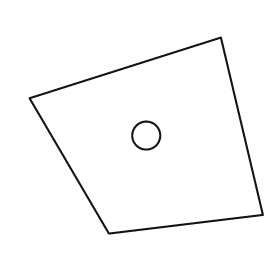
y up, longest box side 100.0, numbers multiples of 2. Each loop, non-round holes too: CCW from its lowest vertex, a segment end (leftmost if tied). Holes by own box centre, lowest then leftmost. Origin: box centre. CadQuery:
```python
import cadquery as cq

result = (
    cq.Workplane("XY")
    .moveTo(-16.0, -42.0)
    .lineTo(50.0, -34.0)
    .lineTo(32.0, 42.0)
    .lineTo(-50.0, 16.0)
    .close()
    .moveTo(0.0, 0.0)
    .circle(6.0)
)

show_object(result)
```